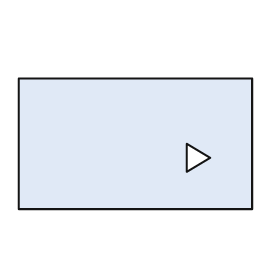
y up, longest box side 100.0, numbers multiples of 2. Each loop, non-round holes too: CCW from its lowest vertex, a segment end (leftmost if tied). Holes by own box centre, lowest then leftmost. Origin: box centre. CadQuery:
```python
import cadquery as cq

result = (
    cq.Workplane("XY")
    .moveTo(-50.0, -28.0)
    .lineTo(50.0, -28.0)
    .lineTo(50.0, 28.0)
    .lineTo(-50.0, 28.0)
    .close()
    .moveTo(22.0, -12.0)
    .lineTo(32.0, -6.0)
    .lineTo(22.0, 0.0)
    .close()
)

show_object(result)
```